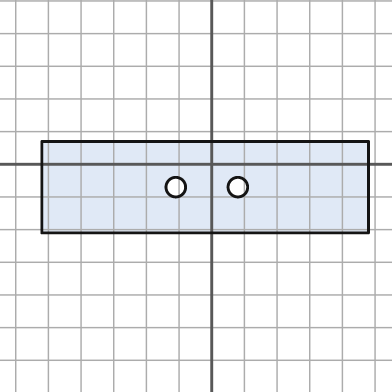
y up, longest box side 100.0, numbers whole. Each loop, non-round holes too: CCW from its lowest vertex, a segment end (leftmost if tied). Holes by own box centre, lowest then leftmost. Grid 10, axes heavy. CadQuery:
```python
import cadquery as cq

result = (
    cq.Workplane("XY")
    .moveTo(-52.0, -21.0)
    .lineTo(48.0, -21.0)
    .lineTo(48.0, 7.0)
    .lineTo(-52.0, 7.0)
    .close()
    .moveTo(-11.0, -7.0)
    .circle(3.0)
    .moveTo(8.0, -7.0)
    .circle(3.0)
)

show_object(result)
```